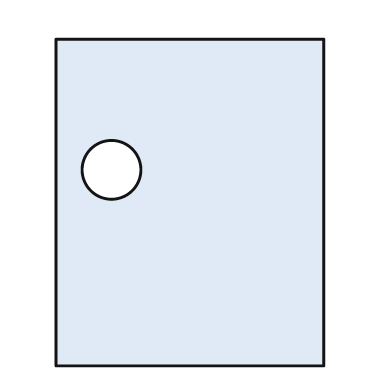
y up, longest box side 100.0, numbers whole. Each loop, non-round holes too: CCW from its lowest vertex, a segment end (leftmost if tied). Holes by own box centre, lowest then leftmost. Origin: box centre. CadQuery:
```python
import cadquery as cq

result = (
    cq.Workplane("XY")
    .moveTo(-41.0, -50.0)
    .lineTo(41.0, -50.0)
    .lineTo(41.0, 50.0)
    .lineTo(-41.0, 50.0)
    .close()
    .moveTo(-24.0, 10.0)
    .circle(9.0)
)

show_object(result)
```